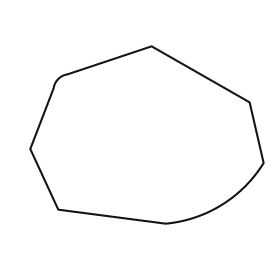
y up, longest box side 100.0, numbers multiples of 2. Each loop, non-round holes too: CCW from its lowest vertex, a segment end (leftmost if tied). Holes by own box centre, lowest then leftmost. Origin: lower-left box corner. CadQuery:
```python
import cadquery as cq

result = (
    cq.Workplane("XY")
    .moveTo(58.0, 0.0)
    .threePointArc((82.0, 8.0), (100.0, 26.0))
    .lineTo(94.0, 52.0)
    .lineTo(52.0, 76.0)
    .lineTo(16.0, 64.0)
    .threePointArc((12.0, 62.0), (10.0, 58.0))
    .lineTo(0.0, 32.0)
    .lineTo(12.0, 6.0)
    .close()
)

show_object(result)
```